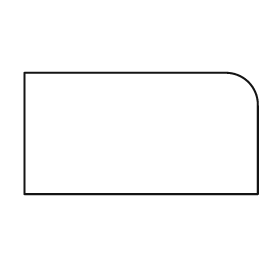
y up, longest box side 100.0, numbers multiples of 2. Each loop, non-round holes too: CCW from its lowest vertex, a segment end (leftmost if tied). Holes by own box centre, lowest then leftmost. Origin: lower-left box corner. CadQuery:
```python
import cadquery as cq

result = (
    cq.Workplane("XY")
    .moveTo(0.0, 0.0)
    .lineTo(100.0, 0.0)
    .lineTo(100.0, 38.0)
    .threePointArc((96.0, 48.0), (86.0, 52.0))
    .lineTo(0.0, 52.0)
    .close()
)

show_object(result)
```